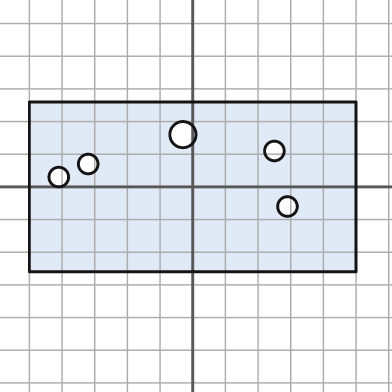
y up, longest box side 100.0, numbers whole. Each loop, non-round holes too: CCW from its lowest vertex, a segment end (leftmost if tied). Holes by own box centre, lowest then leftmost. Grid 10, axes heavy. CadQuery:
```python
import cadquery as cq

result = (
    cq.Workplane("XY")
    .moveTo(-50.0, -26.0)
    .lineTo(50.0, -26.0)
    .lineTo(50.0, 26.0)
    .lineTo(-50.0, 26.0)
    .close()
    .moveTo(29.0, -6.0)
    .circle(3.0)
    .moveTo(-41.0, 3.0)
    .circle(3.0)
    .moveTo(-32.0, 7.0)
    .circle(3.0)
    .moveTo(25.0, 11.0)
    .circle(3.0)
    .moveTo(-3.0, 16.0)
    .circle(4.0)
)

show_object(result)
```